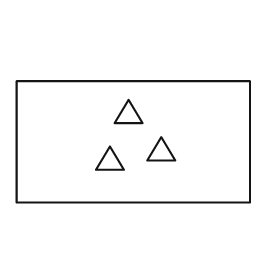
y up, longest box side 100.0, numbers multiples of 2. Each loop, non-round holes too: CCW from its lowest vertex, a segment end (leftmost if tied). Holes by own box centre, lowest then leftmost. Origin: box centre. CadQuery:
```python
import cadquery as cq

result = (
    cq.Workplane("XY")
    .moveTo(-50.0, -26.0)
    .lineTo(50.0, -26.0)
    .lineTo(50.0, 26.0)
    .lineTo(-50.0, 26.0)
    .close()
    .moveTo(-16.0, -12.0)
    .lineTo(-4.0, -12.0)
    .lineTo(-10.0, -2.0)
    .close()
    .moveTo(6.0, -8.0)
    .lineTo(18.0, -8.0)
    .lineTo(12.0, 2.0)
    .close()
    .moveTo(-8.0, 8.0)
    .lineTo(4.0, 8.0)
    .lineTo(-2.0, 18.0)
    .close()
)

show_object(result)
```